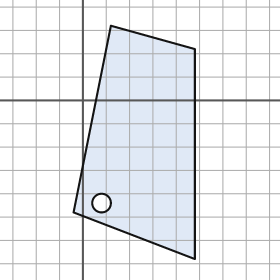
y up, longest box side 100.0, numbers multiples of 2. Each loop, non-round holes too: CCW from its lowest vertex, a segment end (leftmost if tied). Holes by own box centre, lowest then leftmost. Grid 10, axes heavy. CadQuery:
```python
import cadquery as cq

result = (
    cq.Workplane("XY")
    .moveTo(48.0, -68.0)
    .lineTo(48.0, 22.0)
    .lineTo(12.0, 32.0)
    .lineTo(-4.0, -48.0)
    .close()
    .moveTo(8.0, -44.0)
    .circle(4.0)
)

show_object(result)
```